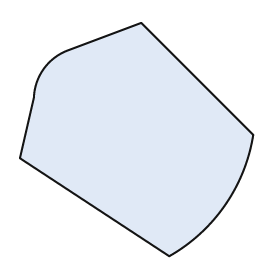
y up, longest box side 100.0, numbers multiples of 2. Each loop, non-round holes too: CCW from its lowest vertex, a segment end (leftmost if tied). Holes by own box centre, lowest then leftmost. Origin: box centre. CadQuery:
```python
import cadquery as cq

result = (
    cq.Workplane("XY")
    .moveTo(14.0, -50.0)
    .threePointArc((38.0, -28.0), (50.0, 2.0))
    .lineTo(2.0, 50.0)
    .lineTo(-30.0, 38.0)
    .threePointArc((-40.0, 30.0), (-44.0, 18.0))
    .lineTo(-50.0, -8.0)
    .close()
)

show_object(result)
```